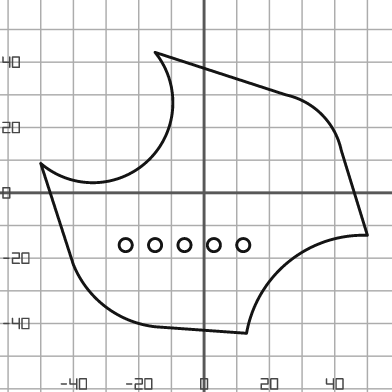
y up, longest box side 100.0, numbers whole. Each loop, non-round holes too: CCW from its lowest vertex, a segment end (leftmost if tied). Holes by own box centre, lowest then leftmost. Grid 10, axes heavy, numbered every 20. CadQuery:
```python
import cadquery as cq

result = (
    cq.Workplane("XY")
    .moveTo(13.0, -43.0)
    .threePointArc((26.0, -21.0), (50.0, -13.0))
    .lineTo(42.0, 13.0)
    .threePointArc((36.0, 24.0), (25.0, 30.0))
    .lineTo(-15.0, 43.0)
    .threePointArc((-17.0, 10.0), (-50.0, 9.0))
    .lineTo(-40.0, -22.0)
    .threePointArc((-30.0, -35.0), (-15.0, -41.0))
    .close()
    .moveTo(-24.0, -16.0)
    .circle(2.0)
    .moveTo(-15.0, -16.0)
    .circle(2.0)
    .moveTo(-6.0, -16.0)
    .circle(2.0)
    .moveTo(3.0, -16.0)
    .circle(2.0)
    .moveTo(12.0, -16.0)
    .circle(2.0)
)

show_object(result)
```